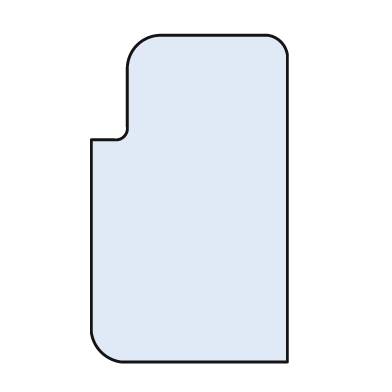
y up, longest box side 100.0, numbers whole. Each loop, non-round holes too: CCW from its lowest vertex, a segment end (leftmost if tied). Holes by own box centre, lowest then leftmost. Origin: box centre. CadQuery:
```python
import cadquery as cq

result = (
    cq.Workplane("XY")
    .moveTo(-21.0, -50.0)
    .lineTo(30.0, -50.0)
    .lineTo(30.0, 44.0)
    .threePointArc((28.0, 48.0), (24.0, 50.0))
    .lineTo(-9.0, 50.0)
    .threePointArc((-16.0, 47.0), (-19.0, 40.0))
    .lineTo(-19.0, 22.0)
    .threePointArc((-20.0, 19.0), (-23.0, 18.0))
    .lineTo(-30.0, 18.0)
    .lineTo(-30.0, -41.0)
    .threePointArc((-27.0, -47.0), (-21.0, -50.0))
    .close()
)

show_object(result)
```